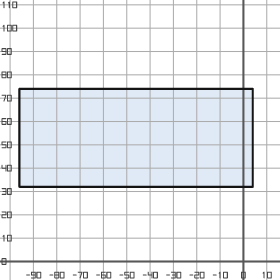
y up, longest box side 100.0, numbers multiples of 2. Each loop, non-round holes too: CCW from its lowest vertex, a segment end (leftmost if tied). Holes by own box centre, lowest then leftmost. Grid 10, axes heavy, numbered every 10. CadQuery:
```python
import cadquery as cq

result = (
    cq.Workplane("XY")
    .moveTo(-96.0, 32.0)
    .lineTo(4.0, 32.0)
    .lineTo(4.0, 74.0)
    .lineTo(-96.0, 74.0)
    .close()
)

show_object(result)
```